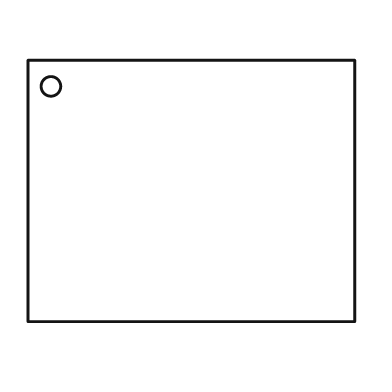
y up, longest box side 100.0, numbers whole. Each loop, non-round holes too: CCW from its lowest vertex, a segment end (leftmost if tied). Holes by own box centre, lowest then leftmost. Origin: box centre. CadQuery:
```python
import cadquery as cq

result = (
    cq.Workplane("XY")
    .moveTo(-50.0, -40.0)
    .lineTo(50.0, -40.0)
    .lineTo(50.0, 40.0)
    .lineTo(-50.0, 40.0)
    .close()
    .moveTo(-43.0, 32.0)
    .circle(3.0)
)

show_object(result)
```